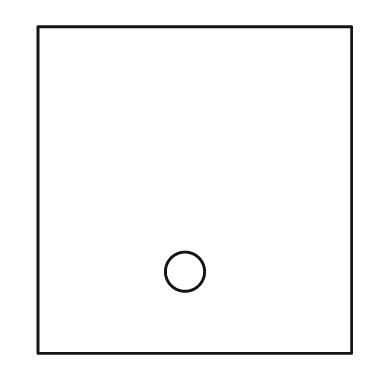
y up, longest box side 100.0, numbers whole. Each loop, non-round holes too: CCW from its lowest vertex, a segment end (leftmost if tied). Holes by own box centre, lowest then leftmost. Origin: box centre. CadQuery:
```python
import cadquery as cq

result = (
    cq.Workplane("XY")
    .moveTo(-48.0, -50.0)
    .lineTo(48.0, -50.0)
    .lineTo(48.0, 50.0)
    .lineTo(-48.0, 50.0)
    .close()
    .moveTo(-3.0, -25.0)
    .circle(6.0)
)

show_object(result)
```